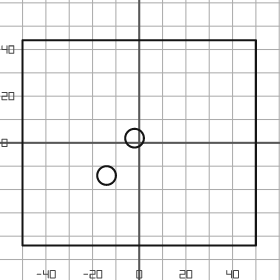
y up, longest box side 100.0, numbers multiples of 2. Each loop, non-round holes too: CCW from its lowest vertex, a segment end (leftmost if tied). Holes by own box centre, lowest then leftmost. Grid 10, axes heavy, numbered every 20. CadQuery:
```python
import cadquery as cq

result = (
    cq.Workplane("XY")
    .moveTo(-50.0, -44.0)
    .lineTo(50.0, -44.0)
    .lineTo(50.0, 44.0)
    .lineTo(-50.0, 44.0)
    .close()
    .moveTo(-14.0, -14.0)
    .circle(4.0)
    .moveTo(-2.0, 2.0)
    .circle(4.0)
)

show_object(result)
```